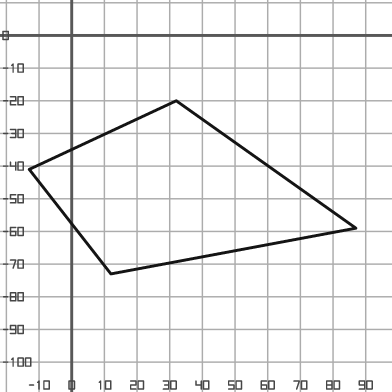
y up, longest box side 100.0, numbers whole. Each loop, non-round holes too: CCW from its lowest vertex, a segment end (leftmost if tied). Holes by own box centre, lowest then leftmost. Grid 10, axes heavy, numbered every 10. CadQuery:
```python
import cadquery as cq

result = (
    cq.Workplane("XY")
    .moveTo(12.0, -73.0)
    .lineTo(87.0, -59.0)
    .lineTo(32.0, -20.0)
    .lineTo(-13.0, -41.0)
    .close()
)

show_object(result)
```